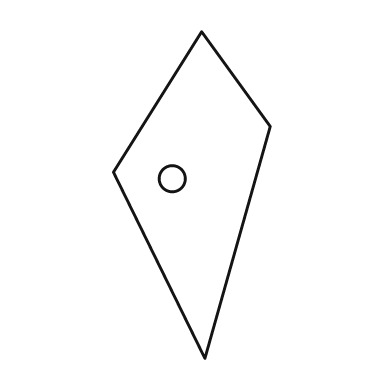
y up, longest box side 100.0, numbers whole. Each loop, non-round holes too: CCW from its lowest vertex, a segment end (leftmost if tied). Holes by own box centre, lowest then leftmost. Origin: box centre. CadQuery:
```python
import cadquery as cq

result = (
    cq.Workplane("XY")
    .moveTo(4.0, -50.0)
    .lineTo(24.0, 21.0)
    .lineTo(3.0, 50.0)
    .lineTo(-24.0, 7.0)
    .close()
    .moveTo(-6.0, 5.0)
    .circle(4.0)
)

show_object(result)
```